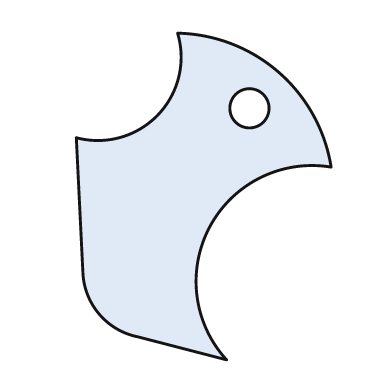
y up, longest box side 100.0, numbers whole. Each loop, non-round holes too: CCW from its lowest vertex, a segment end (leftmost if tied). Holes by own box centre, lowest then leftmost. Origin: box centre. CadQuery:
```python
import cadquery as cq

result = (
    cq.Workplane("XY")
    .moveTo(7.0, -50.0)
    .threePointArc((2.0, -9.0), (39.0, 9.0))
    .threePointArc((23.0, 38.0), (-8.0, 50.0))
    .threePointArc((-14.0, 25.0), (-39.0, 18.0))
    .lineTo(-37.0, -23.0)
    .threePointArc((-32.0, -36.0), (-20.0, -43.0))
    .close()
    .moveTo(14.0, 27.0)
    .circle(6.0)
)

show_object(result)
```